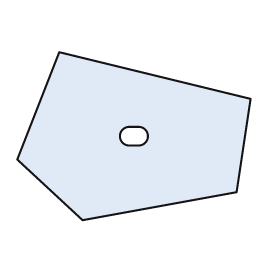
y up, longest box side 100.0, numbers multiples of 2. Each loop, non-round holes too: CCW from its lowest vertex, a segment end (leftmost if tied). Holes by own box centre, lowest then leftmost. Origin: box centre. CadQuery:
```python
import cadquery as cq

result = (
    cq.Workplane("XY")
    .moveTo(-22.0, -36.0)
    .lineTo(44.0, -24.0)
    .lineTo(50.0, 16.0)
    .lineTo(-32.0, 36.0)
    .lineTo(-50.0, -10.0)
    .close()
    .moveTo(-2.0, -4.0)
    .lineTo(2.0, -4.0)
    .threePointArc((6.0, 0.0), (2.0, 4.0))
    .lineTo(-2.0, 4.0)
    .threePointArc((-6.0, 0.0), (-2.0, -4.0))
    .close()
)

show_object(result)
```